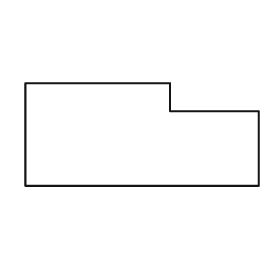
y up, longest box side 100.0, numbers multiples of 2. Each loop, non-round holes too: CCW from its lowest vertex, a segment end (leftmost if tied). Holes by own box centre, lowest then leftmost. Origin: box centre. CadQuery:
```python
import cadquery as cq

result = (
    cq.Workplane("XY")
    .moveTo(-50.0, -22.0)
    .lineTo(50.0, -22.0)
    .lineTo(50.0, 10.0)
    .lineTo(12.0, 10.0)
    .lineTo(12.0, 22.0)
    .lineTo(-50.0, 22.0)
    .close()
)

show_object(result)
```